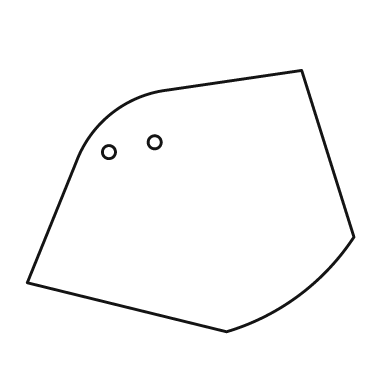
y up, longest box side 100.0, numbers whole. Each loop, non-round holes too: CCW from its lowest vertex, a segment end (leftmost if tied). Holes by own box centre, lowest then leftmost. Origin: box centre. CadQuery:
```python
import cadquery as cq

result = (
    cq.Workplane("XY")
    .moveTo(11.0, -40.0)
    .threePointArc((33.0, -29.0), (50.0, -11.0))
    .lineTo(34.0, 40.0)
    .lineTo(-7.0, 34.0)
    .threePointArc((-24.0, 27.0), (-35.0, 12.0))
    .lineTo(-50.0, -25.0)
    .close()
    .moveTo(-25.0, 15.0)
    .circle(2.0)
    .moveTo(-11.0, 18.0)
    .circle(2.0)
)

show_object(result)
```